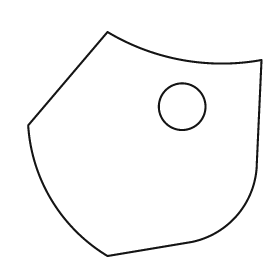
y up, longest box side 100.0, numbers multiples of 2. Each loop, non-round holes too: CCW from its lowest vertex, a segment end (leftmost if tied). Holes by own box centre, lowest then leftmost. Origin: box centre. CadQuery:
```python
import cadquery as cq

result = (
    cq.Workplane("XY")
    .moveTo(-16.0, -48.0)
    .lineTo(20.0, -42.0)
    .threePointArc((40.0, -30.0), (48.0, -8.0))
    .lineTo(50.0, 36.0)
    .threePointArc((16.0, 36.0), (-16.0, 48.0))
    .lineTo(-50.0, 8.0)
    .threePointArc((-40.0, -24.0), (-16.0, -48.0))
    .close()
    .moveTo(16.0, 16.0)
    .circle(10.0)
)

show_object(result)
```